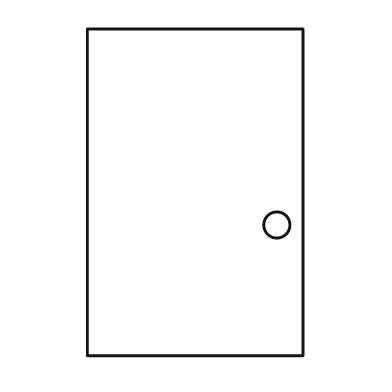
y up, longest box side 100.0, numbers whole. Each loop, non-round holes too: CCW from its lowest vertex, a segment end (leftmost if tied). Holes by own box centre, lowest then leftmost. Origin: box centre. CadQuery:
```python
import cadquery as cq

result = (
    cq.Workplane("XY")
    .moveTo(-33.0, -50.0)
    .lineTo(33.0, -50.0)
    .lineTo(33.0, 50.0)
    .lineTo(-33.0, 50.0)
    .close()
    .moveTo(25.0, -10.0)
    .circle(4.0)
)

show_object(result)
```